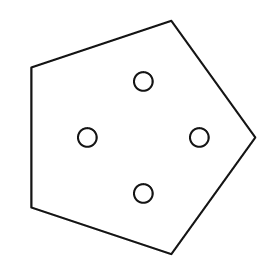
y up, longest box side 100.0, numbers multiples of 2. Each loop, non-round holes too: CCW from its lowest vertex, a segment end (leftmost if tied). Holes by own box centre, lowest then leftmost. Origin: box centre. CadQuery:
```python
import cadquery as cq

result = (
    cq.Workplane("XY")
    .moveTo(12.0, -50.0)
    .lineTo(48.0, 0.0)
    .lineTo(12.0, 50.0)
    .lineTo(-48.0, 30.0)
    .lineTo(-48.0, -30.0)
    .close()
    .moveTo(0.0, -24.0)
    .circle(4.0)
    .moveTo(-24.0, 0.0)
    .circle(4.0)
    .moveTo(24.0, 0.0)
    .circle(4.0)
    .moveTo(0.0, 24.0)
    .circle(4.0)
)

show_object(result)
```